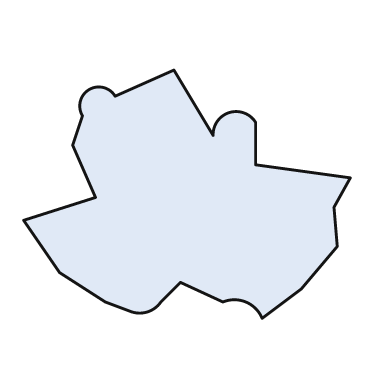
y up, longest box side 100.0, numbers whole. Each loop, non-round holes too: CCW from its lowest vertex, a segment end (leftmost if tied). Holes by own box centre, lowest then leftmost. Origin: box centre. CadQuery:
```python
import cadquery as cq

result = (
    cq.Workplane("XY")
    .moveTo(23.0, -38.0)
    .lineTo(35.0, -29.0)
    .lineTo(46.0, -16.0)
    .lineTo(45.0, -4.0)
    .lineTo(50.0, 5.0)
    .lineTo(21.0, 9.0)
    .lineTo(21.0, 22.0)
    .threePointArc((13.0, 25.0), (8.0, 18.0))
    .lineTo(-4.0, 38.0)
    .lineTo(-22.0, 30.0)
    .threePointArc((-30.0, 32.0), (-32.0, 24.0))
    .lineTo(-35.0, 15.0)
    .lineTo(-28.0, -1.0)
    .lineTo(-50.0, -8.0)
    .lineTo(-39.0, -24.0)
    .lineTo(-25.0, -33.0)
    .lineTo(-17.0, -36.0)
    .threePointArc((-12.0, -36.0), (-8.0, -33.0))
    .lineTo(-2.0, -27.0)
    .lineTo(11.0, -33.0)
    .threePointArc((18.0, -33.0), (23.0, -38.0))
    .close()
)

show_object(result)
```